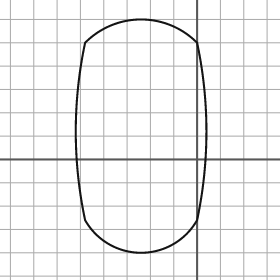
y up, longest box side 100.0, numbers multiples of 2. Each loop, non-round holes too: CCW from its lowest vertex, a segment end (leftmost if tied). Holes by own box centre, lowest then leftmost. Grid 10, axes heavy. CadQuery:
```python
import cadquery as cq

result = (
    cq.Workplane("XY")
    .moveTo(-48.0, -26.0)
    .threePointArc((-24.0, -40.0), (0.0, -26.0))
    .threePointArc((4.0, 12.0), (0.0, 50.0))
    .threePointArc((-24.0, 60.0), (-48.0, 50.0))
    .threePointArc((-52.0, 12.0), (-48.0, -26.0))
    .close()
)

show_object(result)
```